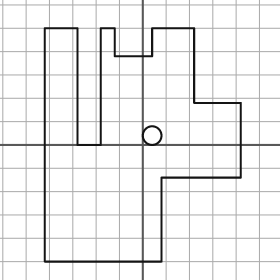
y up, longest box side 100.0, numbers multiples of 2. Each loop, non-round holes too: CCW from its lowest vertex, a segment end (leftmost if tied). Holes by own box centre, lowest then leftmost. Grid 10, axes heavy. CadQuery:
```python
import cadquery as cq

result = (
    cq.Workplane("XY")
    .moveTo(-42.0, -50.0)
    .lineTo(8.0, -50.0)
    .lineTo(8.0, -14.0)
    .lineTo(42.0, -14.0)
    .lineTo(42.0, 18.0)
    .lineTo(22.0, 18.0)
    .lineTo(22.0, 50.0)
    .lineTo(4.0, 50.0)
    .lineTo(4.0, 38.0)
    .lineTo(-12.0, 38.0)
    .lineTo(-12.0, 50.0)
    .lineTo(-18.0, 50.0)
    .lineTo(-18.0, 0.0)
    .lineTo(-28.0, 0.0)
    .lineTo(-28.0, 50.0)
    .lineTo(-42.0, 50.0)
    .close()
    .moveTo(4.0, 4.0)
    .circle(4.0)
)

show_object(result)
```